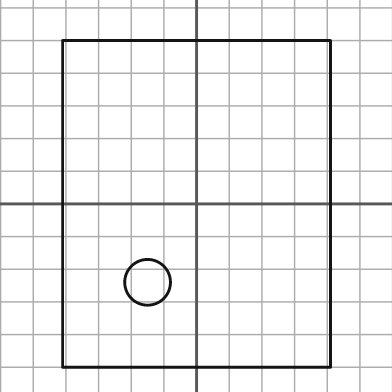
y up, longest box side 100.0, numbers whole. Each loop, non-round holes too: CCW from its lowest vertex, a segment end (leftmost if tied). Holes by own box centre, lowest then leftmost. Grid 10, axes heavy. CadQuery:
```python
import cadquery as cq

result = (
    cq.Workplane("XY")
    .moveTo(-41.0, -50.0)
    .lineTo(41.0, -50.0)
    .lineTo(41.0, 50.0)
    .lineTo(-41.0, 50.0)
    .close()
    .moveTo(-15.0, -24.0)
    .circle(7.0)
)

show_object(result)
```